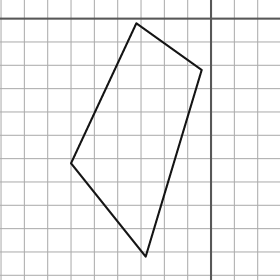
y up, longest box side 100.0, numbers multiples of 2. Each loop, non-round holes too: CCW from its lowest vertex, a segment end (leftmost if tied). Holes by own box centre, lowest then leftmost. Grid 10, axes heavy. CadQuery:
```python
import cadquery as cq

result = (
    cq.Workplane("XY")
    .moveTo(-28.0, -102.0)
    .lineTo(-4.0, -22.0)
    .lineTo(-32.0, -2.0)
    .lineTo(-60.0, -62.0)
    .close()
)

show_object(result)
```